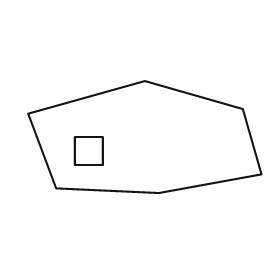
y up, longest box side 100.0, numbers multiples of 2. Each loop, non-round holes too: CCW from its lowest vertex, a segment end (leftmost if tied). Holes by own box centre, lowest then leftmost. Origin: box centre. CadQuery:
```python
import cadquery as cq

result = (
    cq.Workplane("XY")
    .moveTo(6.0, -24.0)
    .lineTo(50.0, -16.0)
    .lineTo(42.0, 12.0)
    .lineTo(0.0, 24.0)
    .lineTo(-50.0, 10.0)
    .lineTo(-38.0, -22.0)
    .close()
    .moveTo(-30.0, -12.0)
    .lineTo(-18.0, -12.0)
    .lineTo(-18.0, 0.0)
    .lineTo(-30.0, 0.0)
    .close()
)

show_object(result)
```